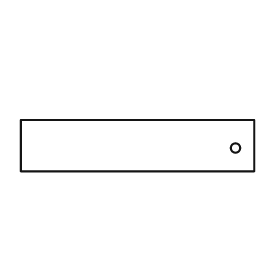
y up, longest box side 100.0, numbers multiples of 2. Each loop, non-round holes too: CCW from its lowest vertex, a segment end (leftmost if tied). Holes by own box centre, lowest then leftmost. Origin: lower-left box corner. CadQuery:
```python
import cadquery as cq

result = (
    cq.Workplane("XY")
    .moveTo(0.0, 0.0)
    .lineTo(100.0, 0.0)
    .lineTo(100.0, 22.0)
    .lineTo(0.0, 22.0)
    .close()
    .moveTo(92.0, 10.0)
    .circle(2.0)
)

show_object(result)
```